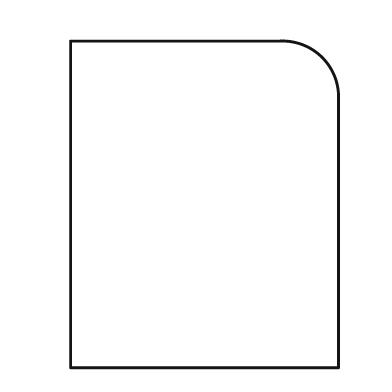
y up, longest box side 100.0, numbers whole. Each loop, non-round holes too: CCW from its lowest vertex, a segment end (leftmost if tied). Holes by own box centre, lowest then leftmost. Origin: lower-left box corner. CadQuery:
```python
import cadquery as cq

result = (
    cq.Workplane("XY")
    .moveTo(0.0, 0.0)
    .lineTo(82.0, 0.0)
    .lineTo(82.0, 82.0)
    .threePointArc((77.0, 95.0), (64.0, 100.0))
    .lineTo(0.0, 100.0)
    .close()
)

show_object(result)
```